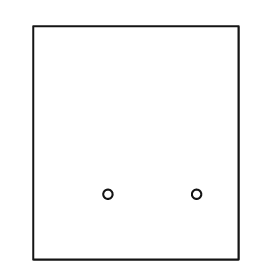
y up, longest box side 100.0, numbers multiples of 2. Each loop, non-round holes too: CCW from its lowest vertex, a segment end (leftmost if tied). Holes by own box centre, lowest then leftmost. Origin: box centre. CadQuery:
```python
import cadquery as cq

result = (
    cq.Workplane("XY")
    .moveTo(-44.0, -50.0)
    .lineTo(44.0, -50.0)
    .lineTo(44.0, 50.0)
    .lineTo(-44.0, 50.0)
    .close()
    .moveTo(-12.0, -22.0)
    .circle(2.0)
    .moveTo(26.0, -22.0)
    .circle(2.0)
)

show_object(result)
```